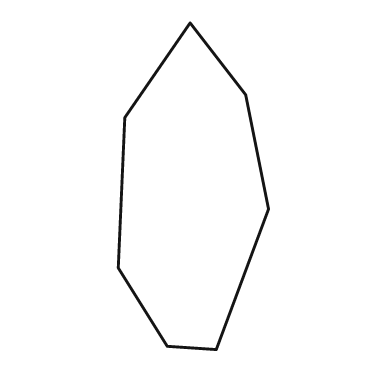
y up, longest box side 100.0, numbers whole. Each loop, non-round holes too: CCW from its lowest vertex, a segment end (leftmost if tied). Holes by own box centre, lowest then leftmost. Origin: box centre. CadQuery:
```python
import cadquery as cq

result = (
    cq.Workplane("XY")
    .moveTo(7.0, -50.0)
    .lineTo(23.0, -7.0)
    .lineTo(16.0, 28.0)
    .lineTo(-1.0, 50.0)
    .lineTo(-21.0, 21.0)
    .lineTo(-23.0, -25.0)
    .lineTo(-8.0, -49.0)
    .close()
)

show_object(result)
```